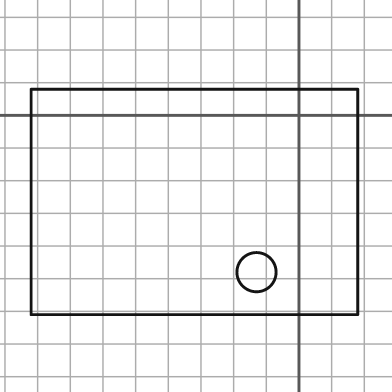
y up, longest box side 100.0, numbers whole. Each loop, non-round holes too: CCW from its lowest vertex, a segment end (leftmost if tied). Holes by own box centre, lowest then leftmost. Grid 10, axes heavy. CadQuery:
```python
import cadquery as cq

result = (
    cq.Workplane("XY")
    .moveTo(-82.0, -61.0)
    .lineTo(18.0, -61.0)
    .lineTo(18.0, 8.0)
    .lineTo(-82.0, 8.0)
    .close()
    .moveTo(-13.0, -48.0)
    .circle(6.0)
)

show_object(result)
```